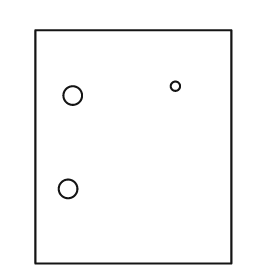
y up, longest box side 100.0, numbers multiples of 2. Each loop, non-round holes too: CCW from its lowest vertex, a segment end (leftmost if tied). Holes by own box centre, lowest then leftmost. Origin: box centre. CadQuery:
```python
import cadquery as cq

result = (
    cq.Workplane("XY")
    .moveTo(-42.0, -50.0)
    .lineTo(42.0, -50.0)
    .lineTo(42.0, 50.0)
    .lineTo(-42.0, 50.0)
    .close()
    .moveTo(-28.0, -18.0)
    .circle(4.0)
    .moveTo(-26.0, 22.0)
    .circle(4.0)
    .moveTo(18.0, 26.0)
    .circle(2.0)
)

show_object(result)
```